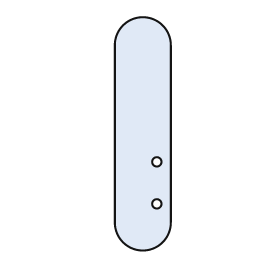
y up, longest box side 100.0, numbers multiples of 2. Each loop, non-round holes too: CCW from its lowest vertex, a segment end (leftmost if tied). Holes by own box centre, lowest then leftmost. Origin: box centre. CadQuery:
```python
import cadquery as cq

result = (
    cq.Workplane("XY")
    .moveTo(-12.0, -38.0)
    .threePointArc((0.0, -50.0), (12.0, -38.0))
    .lineTo(12.0, 38.0)
    .threePointArc((0.0, 50.0), (-12.0, 38.0))
    .close()
    .moveTo(6.0, -30.0)
    .circle(2.0)
    .moveTo(6.0, -12.0)
    .circle(2.0)
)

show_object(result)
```